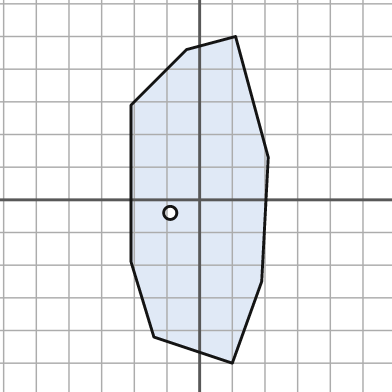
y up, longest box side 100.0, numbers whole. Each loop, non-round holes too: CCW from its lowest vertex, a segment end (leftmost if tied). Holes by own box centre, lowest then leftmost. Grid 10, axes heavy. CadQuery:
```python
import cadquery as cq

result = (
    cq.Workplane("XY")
    .moveTo(10.0, -50.0)
    .lineTo(19.0, -25.0)
    .lineTo(21.0, 13.0)
    .lineTo(11.0, 50.0)
    .lineTo(-4.0, 46.0)
    .lineTo(-21.0, 29.0)
    .lineTo(-21.0, -19.0)
    .lineTo(-14.0, -42.0)
    .close()
    .moveTo(-9.0, -4.0)
    .circle(2.0)
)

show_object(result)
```